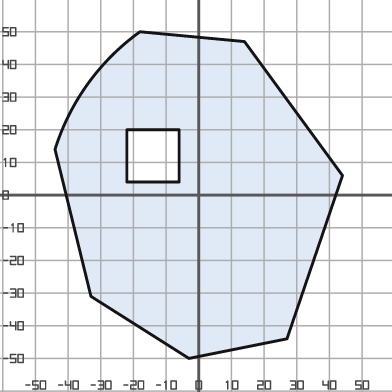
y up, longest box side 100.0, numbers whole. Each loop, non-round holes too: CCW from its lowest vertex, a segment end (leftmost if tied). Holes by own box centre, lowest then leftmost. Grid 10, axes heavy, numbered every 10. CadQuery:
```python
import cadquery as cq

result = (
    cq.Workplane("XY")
    .moveTo(-3.0, -50.0)
    .lineTo(27.0, -44.0)
    .lineTo(44.0, 6.0)
    .lineTo(14.0, 47.0)
    .lineTo(-18.0, 50.0)
    .threePointArc((-34.0, 34.0), (-44.0, 14.0))
    .lineTo(-33.0, -31.0)
    .close()
    .moveTo(-22.0, 4.0)
    .lineTo(-6.0, 4.0)
    .lineTo(-6.0, 20.0)
    .lineTo(-22.0, 20.0)
    .close()
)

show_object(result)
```